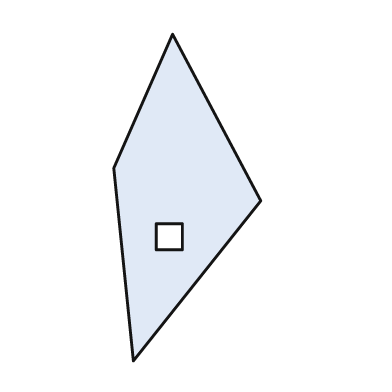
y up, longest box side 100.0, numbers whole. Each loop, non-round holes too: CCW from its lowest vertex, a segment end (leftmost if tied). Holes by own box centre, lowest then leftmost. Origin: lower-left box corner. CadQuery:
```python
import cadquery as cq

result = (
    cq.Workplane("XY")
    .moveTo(6.0, 0.0)
    .lineTo(45.0, 49.0)
    .lineTo(18.0, 100.0)
    .lineTo(0.0, 59.0)
    .close()
    .moveTo(13.0, 34.0)
    .lineTo(21.0, 34.0)
    .lineTo(21.0, 42.0)
    .lineTo(13.0, 42.0)
    .close()
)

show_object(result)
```